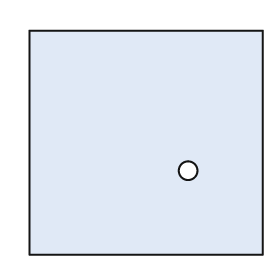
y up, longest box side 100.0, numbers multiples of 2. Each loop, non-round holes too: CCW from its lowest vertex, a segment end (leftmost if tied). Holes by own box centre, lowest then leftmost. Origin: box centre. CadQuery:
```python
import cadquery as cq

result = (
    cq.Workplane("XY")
    .moveTo(-50.0, -48.0)
    .lineTo(50.0, -48.0)
    .lineTo(50.0, 48.0)
    .lineTo(-50.0, 48.0)
    .close()
    .moveTo(18.0, -12.0)
    .circle(4.0)
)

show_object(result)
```